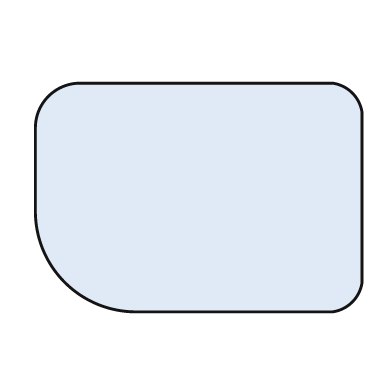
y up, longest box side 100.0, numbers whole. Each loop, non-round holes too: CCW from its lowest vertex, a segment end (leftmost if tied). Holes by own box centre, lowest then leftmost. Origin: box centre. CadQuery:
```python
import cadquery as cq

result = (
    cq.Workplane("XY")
    .moveTo(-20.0, -35.0)
    .lineTo(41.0, -35.0)
    .threePointArc((47.0, -32.0), (50.0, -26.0))
    .lineTo(50.0, 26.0)
    .threePointArc((47.0, 32.0), (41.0, 35.0))
    .lineTo(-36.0, 35.0)
    .threePointArc((-46.0, 31.0), (-50.0, 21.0))
    .lineTo(-50.0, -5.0)
    .threePointArc((-41.0, -26.0), (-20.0, -35.0))
    .close()
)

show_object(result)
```